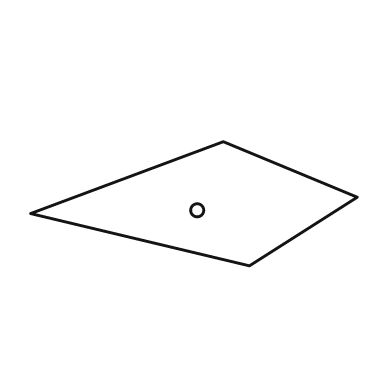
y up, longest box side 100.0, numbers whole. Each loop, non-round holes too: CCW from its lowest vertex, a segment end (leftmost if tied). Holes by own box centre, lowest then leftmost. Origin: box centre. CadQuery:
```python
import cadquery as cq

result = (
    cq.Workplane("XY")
    .moveTo(17.0, -19.0)
    .lineTo(50.0, 2.0)
    .lineTo(9.0, 19.0)
    .lineTo(-50.0, -3.0)
    .close()
    .moveTo(1.0, -2.0)
    .circle(2.0)
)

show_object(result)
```